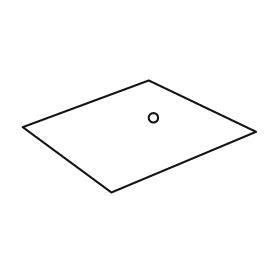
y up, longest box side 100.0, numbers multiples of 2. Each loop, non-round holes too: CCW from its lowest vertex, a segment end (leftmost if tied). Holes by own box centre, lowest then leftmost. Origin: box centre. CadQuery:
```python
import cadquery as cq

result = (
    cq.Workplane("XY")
    .moveTo(-12.0, -24.0)
    .lineTo(50.0, 2.0)
    .lineTo(4.0, 24.0)
    .lineTo(-50.0, 4.0)
    .close()
    .moveTo(6.0, 8.0)
    .circle(2.0)
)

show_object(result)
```